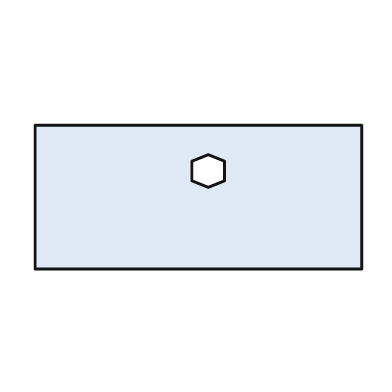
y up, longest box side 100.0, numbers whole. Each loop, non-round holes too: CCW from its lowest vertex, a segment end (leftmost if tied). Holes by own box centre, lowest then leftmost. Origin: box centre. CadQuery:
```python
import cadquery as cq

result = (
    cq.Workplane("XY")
    .moveTo(-50.0, -22.0)
    .lineTo(50.0, -22.0)
    .lineTo(50.0, 22.0)
    .lineTo(-50.0, 22.0)
    .close()
    .moveTo(3.0, 3.0)
    .lineTo(8.0, 5.0)
    .lineTo(8.0, 11.0)
    .lineTo(3.0, 13.0)
    .lineTo(-2.0, 11.0)
    .lineTo(-2.0, 5.0)
    .close()
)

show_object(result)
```